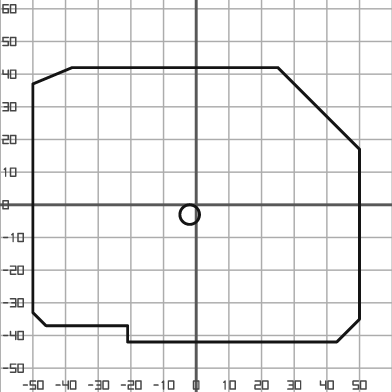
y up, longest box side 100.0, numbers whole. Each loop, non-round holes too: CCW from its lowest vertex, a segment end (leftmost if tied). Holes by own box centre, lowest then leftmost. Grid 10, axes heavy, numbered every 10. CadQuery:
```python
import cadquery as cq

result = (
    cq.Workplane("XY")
    .moveTo(-21.0, -42.0)
    .lineTo(43.0, -42.0)
    .lineTo(50.0, -35.0)
    .lineTo(50.0, 17.0)
    .lineTo(25.0, 42.0)
    .lineTo(-38.0, 42.0)
    .lineTo(-50.0, 37.0)
    .lineTo(-50.0, -33.0)
    .lineTo(-46.0, -37.0)
    .lineTo(-21.0, -37.0)
    .close()
    .moveTo(-2.0, -3.0)
    .circle(3.0)
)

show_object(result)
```